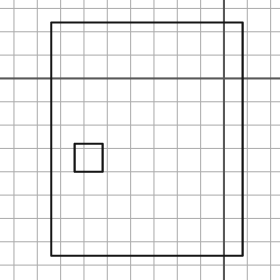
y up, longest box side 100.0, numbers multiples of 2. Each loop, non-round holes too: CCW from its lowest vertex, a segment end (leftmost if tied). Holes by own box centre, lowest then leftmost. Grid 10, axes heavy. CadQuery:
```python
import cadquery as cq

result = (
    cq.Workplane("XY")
    .moveTo(-74.0, -76.0)
    .lineTo(8.0, -76.0)
    .lineTo(8.0, 24.0)
    .lineTo(-74.0, 24.0)
    .close()
    .moveTo(-64.0, -40.0)
    .lineTo(-52.0, -40.0)
    .lineTo(-52.0, -28.0)
    .lineTo(-64.0, -28.0)
    .close()
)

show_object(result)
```